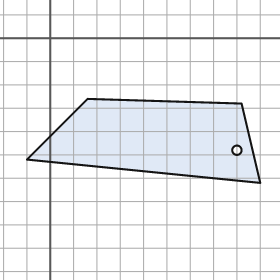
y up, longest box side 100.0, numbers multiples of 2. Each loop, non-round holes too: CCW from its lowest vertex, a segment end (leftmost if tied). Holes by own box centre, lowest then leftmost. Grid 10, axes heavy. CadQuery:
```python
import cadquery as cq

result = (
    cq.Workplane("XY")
    .moveTo(90.0, -62.0)
    .lineTo(82.0, -28.0)
    .lineTo(16.0, -26.0)
    .lineTo(-10.0, -52.0)
    .close()
    .moveTo(80.0, -48.0)
    .circle(2.0)
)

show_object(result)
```